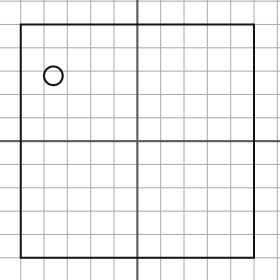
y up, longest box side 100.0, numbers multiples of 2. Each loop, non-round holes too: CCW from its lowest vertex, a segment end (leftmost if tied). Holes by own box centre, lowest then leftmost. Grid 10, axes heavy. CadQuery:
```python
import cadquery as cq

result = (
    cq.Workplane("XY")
    .moveTo(-50.0, -50.0)
    .lineTo(50.0, -50.0)
    .lineTo(50.0, 50.0)
    .lineTo(-50.0, 50.0)
    .close()
    .moveTo(-36.0, 28.0)
    .circle(4.0)
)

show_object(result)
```